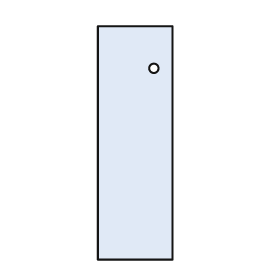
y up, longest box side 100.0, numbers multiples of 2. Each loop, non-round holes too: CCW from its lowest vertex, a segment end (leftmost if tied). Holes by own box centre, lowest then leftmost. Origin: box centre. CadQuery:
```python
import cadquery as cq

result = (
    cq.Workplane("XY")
    .moveTo(-16.0, -50.0)
    .lineTo(16.0, -50.0)
    .lineTo(16.0, 50.0)
    .lineTo(-16.0, 50.0)
    .close()
    .moveTo(8.0, 32.0)
    .circle(2.0)
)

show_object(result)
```